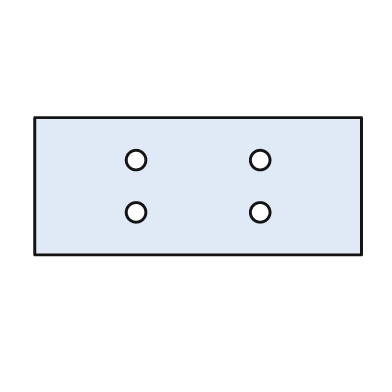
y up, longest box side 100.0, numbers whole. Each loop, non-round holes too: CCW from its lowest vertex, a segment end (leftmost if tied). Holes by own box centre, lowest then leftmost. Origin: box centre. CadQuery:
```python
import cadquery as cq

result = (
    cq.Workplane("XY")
    .moveTo(-50.0, -21.0)
    .lineTo(50.0, -21.0)
    .lineTo(50.0, 21.0)
    .lineTo(-50.0, 21.0)
    .close()
    .moveTo(-19.0, -8.0)
    .circle(3.0)
    .moveTo(19.0, -8.0)
    .circle(3.0)
    .moveTo(-19.0, 8.0)
    .circle(3.0)
    .moveTo(19.0, 8.0)
    .circle(3.0)
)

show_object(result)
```